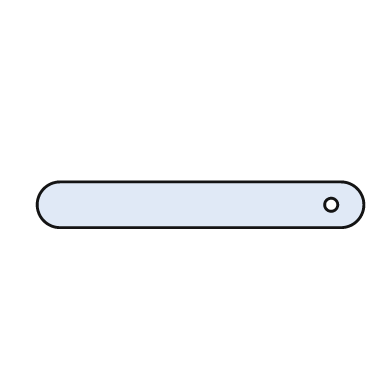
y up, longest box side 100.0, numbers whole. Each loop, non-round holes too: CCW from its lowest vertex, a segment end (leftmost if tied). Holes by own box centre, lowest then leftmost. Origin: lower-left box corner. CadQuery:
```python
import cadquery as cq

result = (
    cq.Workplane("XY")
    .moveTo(7.0, 0.0)
    .lineTo(93.0, 0.0)
    .threePointArc((100.0, 7.0), (93.0, 14.0))
    .lineTo(7.0, 14.0)
    .threePointArc((0.0, 7.0), (7.0, 0.0))
    .close()
    .moveTo(90.0, 7.0)
    .circle(2.0)
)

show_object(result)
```